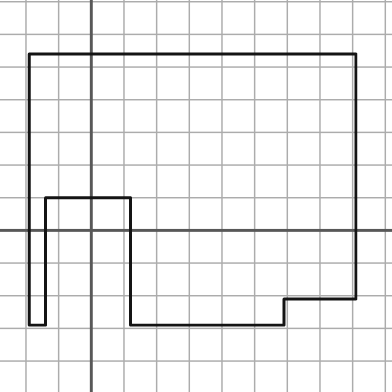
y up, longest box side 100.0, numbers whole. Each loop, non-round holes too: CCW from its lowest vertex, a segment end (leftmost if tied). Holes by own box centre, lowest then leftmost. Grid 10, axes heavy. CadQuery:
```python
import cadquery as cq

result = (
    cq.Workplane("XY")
    .moveTo(-19.0, -29.0)
    .lineTo(-14.0, -29.0)
    .lineTo(-14.0, 10.0)
    .lineTo(12.0, 10.0)
    .lineTo(12.0, -29.0)
    .lineTo(59.0, -29.0)
    .lineTo(59.0, -21.0)
    .lineTo(81.0, -21.0)
    .lineTo(81.0, 54.0)
    .lineTo(-19.0, 54.0)
    .close()
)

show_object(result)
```